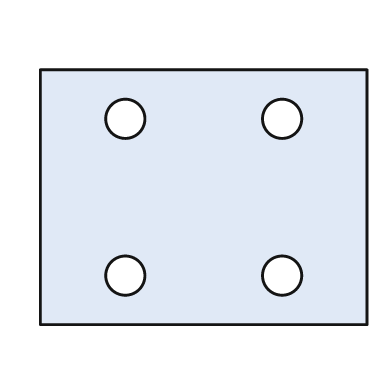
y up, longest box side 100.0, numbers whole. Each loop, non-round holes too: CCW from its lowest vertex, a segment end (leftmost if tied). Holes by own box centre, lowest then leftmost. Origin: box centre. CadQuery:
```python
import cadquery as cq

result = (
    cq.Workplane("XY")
    .moveTo(-50.0, -39.0)
    .lineTo(50.0, -39.0)
    .lineTo(50.0, 39.0)
    .lineTo(-50.0, 39.0)
    .close()
    .moveTo(-24.0, -24.0)
    .circle(6.0)
    .moveTo(24.0, -24.0)
    .circle(6.0)
    .moveTo(-24.0, 24.0)
    .circle(6.0)
    .moveTo(24.0, 24.0)
    .circle(6.0)
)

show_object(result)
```